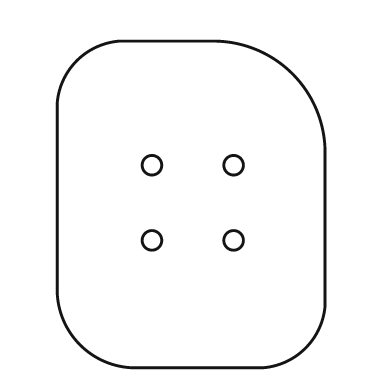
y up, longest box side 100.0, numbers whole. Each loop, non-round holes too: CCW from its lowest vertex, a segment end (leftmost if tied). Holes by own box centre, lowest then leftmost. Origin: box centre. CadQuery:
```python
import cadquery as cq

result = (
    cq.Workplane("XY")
    .moveTo(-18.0, -50.0)
    .lineTo(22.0, -50.0)
    .threePointArc((35.0, -44.0), (41.0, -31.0))
    .lineTo(41.0, 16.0)
    .threePointArc((31.0, 40.0), (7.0, 50.0))
    .lineTo(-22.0, 50.0)
    .threePointArc((-35.0, 44.0), (-41.0, 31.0))
    .lineTo(-41.0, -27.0)
    .threePointArc((-34.0, -43.0), (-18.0, -50.0))
    .close()
    .moveTo(-12.0, -11.0)
    .circle(3.0)
    .moveTo(13.0, -11.0)
    .circle(3.0)
    .moveTo(-12.0, 12.0)
    .circle(3.0)
    .moveTo(13.0, 12.0)
    .circle(3.0)
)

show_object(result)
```